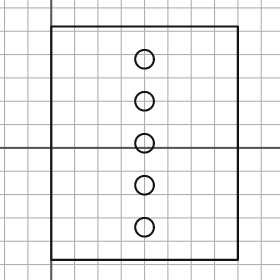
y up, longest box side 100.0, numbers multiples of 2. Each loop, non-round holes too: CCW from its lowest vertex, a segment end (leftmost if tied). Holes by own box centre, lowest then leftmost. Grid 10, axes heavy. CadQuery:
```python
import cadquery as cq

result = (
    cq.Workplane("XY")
    .moveTo(0.0, -48.0)
    .lineTo(80.0, -48.0)
    .lineTo(80.0, 52.0)
    .lineTo(0.0, 52.0)
    .close()
    .moveTo(40.0, -34.0)
    .circle(4.0)
    .moveTo(40.0, -16.0)
    .circle(4.0)
    .moveTo(40.0, 2.0)
    .circle(4.0)
    .moveTo(40.0, 20.0)
    .circle(4.0)
    .moveTo(40.0, 38.0)
    .circle(4.0)
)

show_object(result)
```